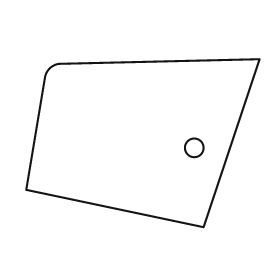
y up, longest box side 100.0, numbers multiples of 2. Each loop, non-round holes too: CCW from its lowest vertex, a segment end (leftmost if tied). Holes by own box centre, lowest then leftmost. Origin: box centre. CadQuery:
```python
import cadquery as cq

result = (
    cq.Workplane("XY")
    .moveTo(26.0, -36.0)
    .lineTo(50.0, 36.0)
    .lineTo(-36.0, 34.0)
    .threePointArc((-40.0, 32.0), (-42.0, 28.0))
    .lineTo(-50.0, -20.0)
    .close()
    .moveTo(22.0, -2.0)
    .circle(4.0)
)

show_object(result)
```